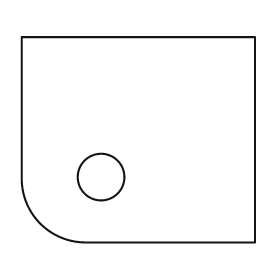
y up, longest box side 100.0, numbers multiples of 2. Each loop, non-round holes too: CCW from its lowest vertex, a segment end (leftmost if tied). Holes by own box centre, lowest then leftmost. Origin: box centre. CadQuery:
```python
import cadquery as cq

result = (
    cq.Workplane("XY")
    .moveTo(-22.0, -44.0)
    .lineTo(50.0, -44.0)
    .lineTo(50.0, 44.0)
    .lineTo(-50.0, 44.0)
    .lineTo(-50.0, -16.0)
    .threePointArc((-42.0, -36.0), (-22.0, -44.0))
    .close()
    .moveTo(-16.0, -16.0)
    .circle(10.0)
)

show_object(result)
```